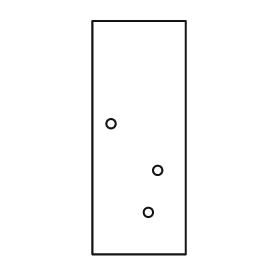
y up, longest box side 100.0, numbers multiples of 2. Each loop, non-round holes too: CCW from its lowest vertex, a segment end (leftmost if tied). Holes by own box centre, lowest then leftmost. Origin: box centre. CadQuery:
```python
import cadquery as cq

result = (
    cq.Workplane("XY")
    .moveTo(-20.0, -50.0)
    .lineTo(20.0, -50.0)
    .lineTo(20.0, 50.0)
    .lineTo(-20.0, 50.0)
    .close()
    .moveTo(4.0, -32.0)
    .circle(2.0)
    .moveTo(8.0, -14.0)
    .circle(2.0)
    .moveTo(-12.0, 6.0)
    .circle(2.0)
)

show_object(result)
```